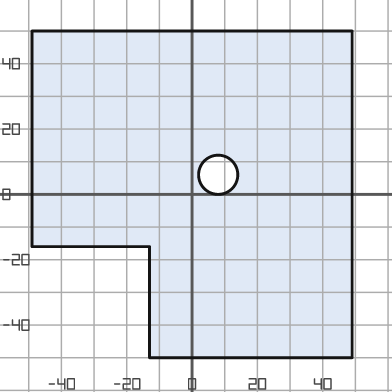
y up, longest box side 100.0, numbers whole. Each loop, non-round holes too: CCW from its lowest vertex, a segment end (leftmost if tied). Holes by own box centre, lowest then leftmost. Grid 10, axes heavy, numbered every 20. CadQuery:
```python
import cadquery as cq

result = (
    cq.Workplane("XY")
    .moveTo(-13.0, -50.0)
    .lineTo(49.0, -50.0)
    .lineTo(49.0, 50.0)
    .lineTo(-49.0, 50.0)
    .lineTo(-49.0, -16.0)
    .lineTo(-13.0, -16.0)
    .close()
    .moveTo(8.0, 6.0)
    .circle(6.0)
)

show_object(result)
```